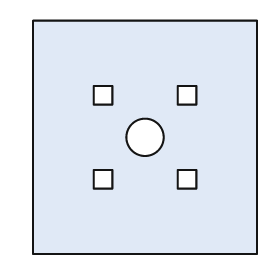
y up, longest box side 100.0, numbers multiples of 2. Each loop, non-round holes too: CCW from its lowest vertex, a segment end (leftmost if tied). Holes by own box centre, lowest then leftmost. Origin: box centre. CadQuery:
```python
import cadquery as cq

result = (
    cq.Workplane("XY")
    .moveTo(-48.0, -50.0)
    .lineTo(48.0, -50.0)
    .lineTo(48.0, 50.0)
    .lineTo(-48.0, 50.0)
    .close()
    .moveTo(-22.0, -22.0)
    .lineTo(-14.0, -22.0)
    .lineTo(-14.0, -14.0)
    .lineTo(-22.0, -14.0)
    .close()
    .moveTo(14.0, -22.0)
    .lineTo(22.0, -22.0)
    .lineTo(22.0, -14.0)
    .lineTo(14.0, -14.0)
    .close()
    .moveTo(0.0, 0.0)
    .circle(8.0)
    .moveTo(-22.0, 14.0)
    .lineTo(-14.0, 14.0)
    .lineTo(-14.0, 22.0)
    .lineTo(-22.0, 22.0)
    .close()
    .moveTo(14.0, 14.0)
    .lineTo(22.0, 14.0)
    .lineTo(22.0, 22.0)
    .lineTo(14.0, 22.0)
    .close()
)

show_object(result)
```